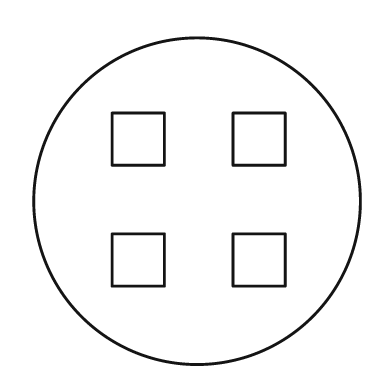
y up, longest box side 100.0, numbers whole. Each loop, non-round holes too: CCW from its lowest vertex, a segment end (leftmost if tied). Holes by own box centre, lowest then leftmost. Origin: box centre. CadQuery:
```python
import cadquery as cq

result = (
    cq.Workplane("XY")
    .moveTo(0.0, 0.0)
    .circle(50.0)
    .moveTo(-26.0, -26.0)
    .lineTo(-10.0, -26.0)
    .lineTo(-10.0, -10.0)
    .lineTo(-26.0, -10.0)
    .close()
    .moveTo(11.0, -26.0)
    .lineTo(27.0, -26.0)
    .lineTo(27.0, -10.0)
    .lineTo(11.0, -10.0)
    .close()
    .moveTo(-26.0, 11.0)
    .lineTo(-10.0, 11.0)
    .lineTo(-10.0, 27.0)
    .lineTo(-26.0, 27.0)
    .close()
    .moveTo(11.0, 11.0)
    .lineTo(27.0, 11.0)
    .lineTo(27.0, 27.0)
    .lineTo(11.0, 27.0)
    .close()
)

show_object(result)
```